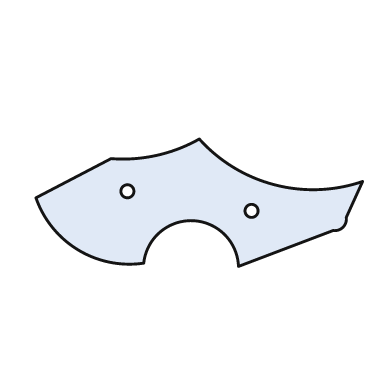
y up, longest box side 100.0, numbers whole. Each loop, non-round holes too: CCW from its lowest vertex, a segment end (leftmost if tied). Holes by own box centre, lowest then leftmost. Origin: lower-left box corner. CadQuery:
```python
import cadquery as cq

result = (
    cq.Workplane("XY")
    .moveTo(62.0, 0.0)
    .lineTo(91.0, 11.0)
    .threePointArc((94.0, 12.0), (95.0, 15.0))
    .lineTo(100.0, 26.0)
    .threePointArc((73.0, 25.0), (50.0, 39.0))
    .threePointArc((37.0, 34.0), (23.0, 33.0))
    .lineTo(0.0, 21.0)
    .threePointArc((13.0, 5.0), (33.0, 1.0))
    .threePointArc((48.0, 14.0), (62.0, 0.0))
    .close()
    .moveTo(66.0, 17.0)
    .circle(2.0)
    .moveTo(28.0, 23.0)
    .circle(2.0)
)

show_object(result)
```